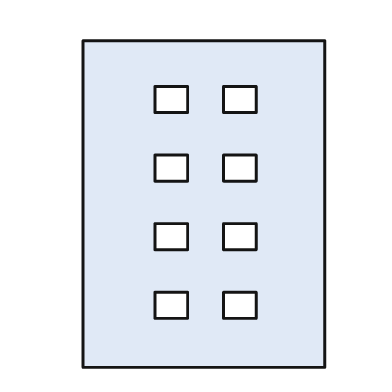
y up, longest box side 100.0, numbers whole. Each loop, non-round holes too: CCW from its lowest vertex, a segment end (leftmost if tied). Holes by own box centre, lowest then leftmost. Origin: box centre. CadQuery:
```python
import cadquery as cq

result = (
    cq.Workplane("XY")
    .moveTo(-37.0, -50.0)
    .lineTo(37.0, -50.0)
    .lineTo(37.0, 50.0)
    .lineTo(-37.0, 50.0)
    .close()
    .moveTo(-15.0, -35.0)
    .lineTo(-5.0, -35.0)
    .lineTo(-5.0, -27.0)
    .lineTo(-15.0, -27.0)
    .close()
    .moveTo(6.0, -35.0)
    .lineTo(16.0, -35.0)
    .lineTo(16.0, -27.0)
    .lineTo(6.0, -27.0)
    .close()
    .moveTo(-15.0, -14.0)
    .lineTo(-5.0, -14.0)
    .lineTo(-5.0, -6.0)
    .lineTo(-15.0, -6.0)
    .close()
    .moveTo(6.0, -14.0)
    .lineTo(16.0, -14.0)
    .lineTo(16.0, -6.0)
    .lineTo(6.0, -6.0)
    .close()
    .moveTo(-15.0, 7.0)
    .lineTo(-5.0, 7.0)
    .lineTo(-5.0, 15.0)
    .lineTo(-15.0, 15.0)
    .close()
    .moveTo(6.0, 7.0)
    .lineTo(16.0, 7.0)
    .lineTo(16.0, 15.0)
    .lineTo(6.0, 15.0)
    .close()
    .moveTo(-15.0, 28.0)
    .lineTo(-5.0, 28.0)
    .lineTo(-5.0, 36.0)
    .lineTo(-15.0, 36.0)
    .close()
    .moveTo(6.0, 28.0)
    .lineTo(16.0, 28.0)
    .lineTo(16.0, 36.0)
    .lineTo(6.0, 36.0)
    .close()
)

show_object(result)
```